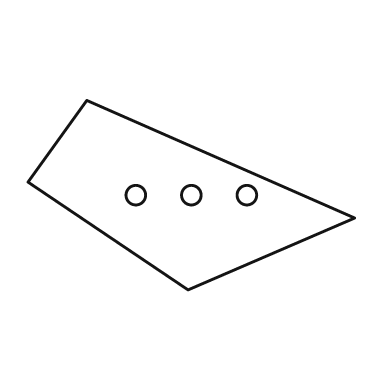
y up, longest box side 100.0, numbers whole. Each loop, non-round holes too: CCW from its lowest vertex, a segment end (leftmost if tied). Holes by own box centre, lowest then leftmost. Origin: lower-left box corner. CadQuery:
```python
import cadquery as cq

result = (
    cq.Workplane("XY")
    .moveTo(49.0, 0.0)
    .lineTo(100.0, 22.0)
    .lineTo(18.0, 58.0)
    .lineTo(0.0, 33.0)
    .close()
    .moveTo(33.0, 29.0)
    .circle(3.0)
    .moveTo(50.0, 29.0)
    .circle(3.0)
    .moveTo(67.0, 29.0)
    .circle(3.0)
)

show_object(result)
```